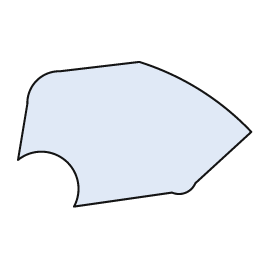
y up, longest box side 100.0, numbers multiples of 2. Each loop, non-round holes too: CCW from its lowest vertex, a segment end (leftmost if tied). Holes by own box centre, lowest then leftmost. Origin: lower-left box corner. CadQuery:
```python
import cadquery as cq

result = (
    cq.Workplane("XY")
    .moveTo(24.0, 0.0)
    .lineTo(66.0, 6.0)
    .threePointArc((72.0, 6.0), (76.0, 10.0))
    .lineTo(100.0, 32.0)
    .threePointArc((78.0, 50.0), (52.0, 62.0))
    .lineTo(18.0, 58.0)
    .threePointArc((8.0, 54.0), (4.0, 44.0))
    .lineTo(0.0, 20.0)
    .threePointArc((20.0, 20.0), (24.0, 0.0))
    .close()
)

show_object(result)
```